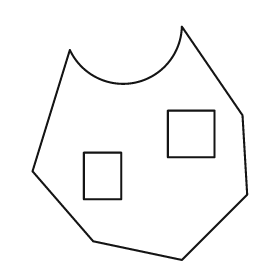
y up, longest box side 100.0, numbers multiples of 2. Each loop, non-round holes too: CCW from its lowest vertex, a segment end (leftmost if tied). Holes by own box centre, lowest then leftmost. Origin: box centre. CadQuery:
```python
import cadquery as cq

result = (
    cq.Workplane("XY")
    .moveTo(18.0, -50.0)
    .lineTo(46.0, -22.0)
    .lineTo(44.0, 12.0)
    .lineTo(18.0, 50.0)
    .threePointArc((-2.0, 26.0), (-30.0, 40.0))
    .lineTo(-46.0, -12.0)
    .lineTo(-20.0, -42.0)
    .close()
    .moveTo(-24.0, -24.0)
    .lineTo(-8.0, -24.0)
    .lineTo(-8.0, -4.0)
    .lineTo(-24.0, -4.0)
    .close()
    .moveTo(12.0, -6.0)
    .lineTo(32.0, -6.0)
    .lineTo(32.0, 14.0)
    .lineTo(12.0, 14.0)
    .close()
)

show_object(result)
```